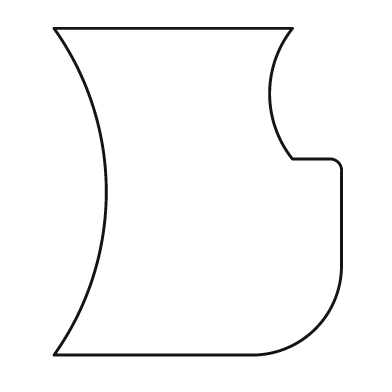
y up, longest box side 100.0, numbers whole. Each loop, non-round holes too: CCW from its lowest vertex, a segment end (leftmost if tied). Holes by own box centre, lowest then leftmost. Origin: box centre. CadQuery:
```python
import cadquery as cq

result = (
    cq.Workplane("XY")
    .moveTo(-44.0, -50.0)
    .lineTo(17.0, -50.0)
    .threePointArc((36.0, -42.0), (44.0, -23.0))
    .lineTo(44.0, 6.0)
    .threePointArc((43.0, 9.0), (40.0, 10.0))
    .lineTo(29.0, 10.0)
    .threePointArc((22.0, 30.0), (29.0, 50.0))
    .lineTo(-44.0, 50.0)
    .threePointArc((-28.0, 0.0), (-44.0, -50.0))
    .close()
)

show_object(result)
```